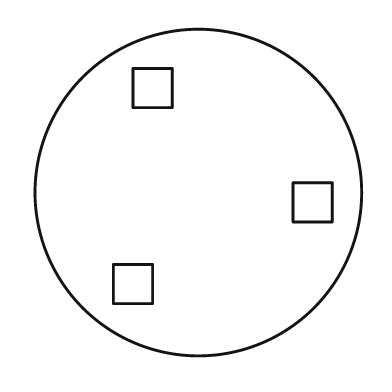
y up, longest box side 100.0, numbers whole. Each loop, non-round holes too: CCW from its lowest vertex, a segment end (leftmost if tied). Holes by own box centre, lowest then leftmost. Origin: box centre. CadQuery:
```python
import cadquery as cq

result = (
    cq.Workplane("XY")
    .moveTo(0.0, 0.0)
    .circle(50.0)
    .moveTo(-26.0, -34.0)
    .lineTo(-14.0, -34.0)
    .lineTo(-14.0, -22.0)
    .lineTo(-26.0, -22.0)
    .close()
    .moveTo(29.0, -9.0)
    .lineTo(41.0, -9.0)
    .lineTo(41.0, 3.0)
    .lineTo(29.0, 3.0)
    .close()
    .moveTo(-20.0, 26.0)
    .lineTo(-8.0, 26.0)
    .lineTo(-8.0, 38.0)
    .lineTo(-20.0, 38.0)
    .close()
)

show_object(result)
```